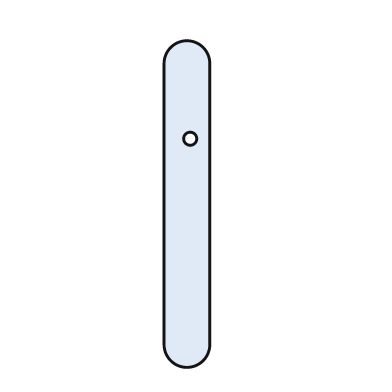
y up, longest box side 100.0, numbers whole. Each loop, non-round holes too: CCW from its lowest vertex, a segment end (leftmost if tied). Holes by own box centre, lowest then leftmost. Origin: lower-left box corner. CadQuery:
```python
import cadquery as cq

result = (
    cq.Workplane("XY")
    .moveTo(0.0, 7.0)
    .threePointArc((7.0, 0.0), (14.0, 7.0))
    .lineTo(14.0, 93.0)
    .threePointArc((7.0, 100.0), (0.0, 93.0))
    .close()
    .moveTo(8.0, 70.0)
    .circle(2.0)
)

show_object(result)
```